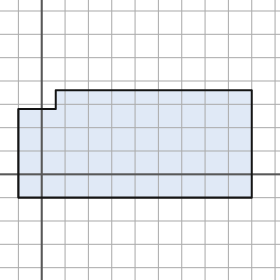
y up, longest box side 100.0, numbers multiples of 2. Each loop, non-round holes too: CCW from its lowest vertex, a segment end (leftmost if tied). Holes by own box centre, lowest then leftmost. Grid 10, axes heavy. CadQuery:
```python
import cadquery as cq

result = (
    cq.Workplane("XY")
    .moveTo(-10.0, -10.0)
    .lineTo(90.0, -10.0)
    .lineTo(90.0, 36.0)
    .lineTo(6.0, 36.0)
    .lineTo(6.0, 28.0)
    .lineTo(-10.0, 28.0)
    .close()
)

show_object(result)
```